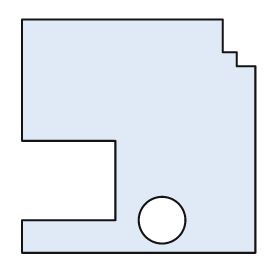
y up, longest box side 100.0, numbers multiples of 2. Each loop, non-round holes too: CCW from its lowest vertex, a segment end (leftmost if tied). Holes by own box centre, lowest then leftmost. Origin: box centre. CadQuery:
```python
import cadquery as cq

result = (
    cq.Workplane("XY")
    .moveTo(-50.0, -50.0)
    .lineTo(50.0, -50.0)
    .lineTo(50.0, 30.0)
    .lineTo(42.0, 30.0)
    .lineTo(42.0, 36.0)
    .lineTo(36.0, 36.0)
    .lineTo(36.0, 50.0)
    .lineTo(-50.0, 50.0)
    .lineTo(-50.0, -2.0)
    .lineTo(-10.0, -2.0)
    .lineTo(-10.0, -36.0)
    .lineTo(-50.0, -36.0)
    .close()
    .moveTo(10.0, -36.0)
    .circle(10.0)
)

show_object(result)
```